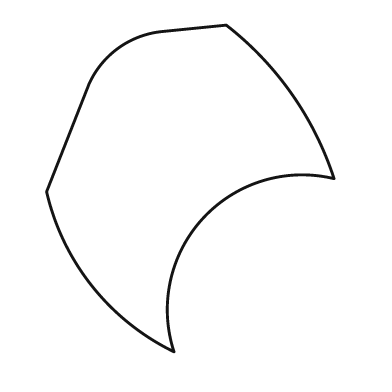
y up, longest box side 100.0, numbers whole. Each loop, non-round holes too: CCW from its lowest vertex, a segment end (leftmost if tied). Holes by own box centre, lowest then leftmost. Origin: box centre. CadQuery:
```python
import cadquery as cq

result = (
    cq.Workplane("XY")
    .moveTo(-5.0, -50.0)
    .threePointArc((4.0, -9.0), (44.0, 3.0))
    .threePointArc((31.0, 29.0), (11.0, 50.0))
    .lineTo(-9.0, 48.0)
    .threePointArc((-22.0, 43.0), (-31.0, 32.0))
    .lineTo(-44.0, -1.0)
    .threePointArc((-30.0, -30.0), (-5.0, -50.0))
    .close()
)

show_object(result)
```